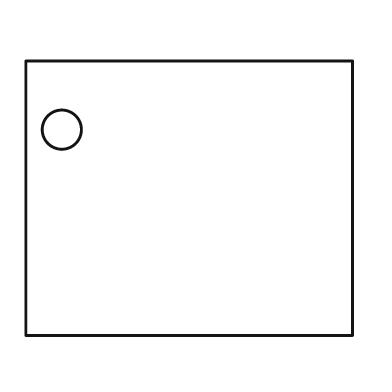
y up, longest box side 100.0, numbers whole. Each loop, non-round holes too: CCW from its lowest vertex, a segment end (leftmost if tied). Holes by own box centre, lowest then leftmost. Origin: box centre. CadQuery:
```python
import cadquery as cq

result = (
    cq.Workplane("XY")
    .moveTo(-50.0, -42.0)
    .lineTo(50.0, -42.0)
    .lineTo(50.0, 42.0)
    .lineTo(-50.0, 42.0)
    .close()
    .moveTo(-39.0, 21.0)
    .circle(6.0)
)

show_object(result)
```